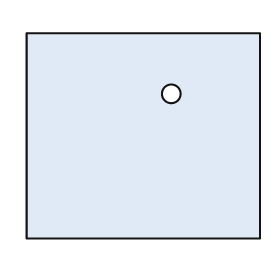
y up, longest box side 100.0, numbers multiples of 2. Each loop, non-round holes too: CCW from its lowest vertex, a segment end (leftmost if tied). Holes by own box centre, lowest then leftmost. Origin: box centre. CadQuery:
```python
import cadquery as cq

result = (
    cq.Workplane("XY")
    .moveTo(-50.0, -44.0)
    .lineTo(50.0, -44.0)
    .lineTo(50.0, 44.0)
    .lineTo(-50.0, 44.0)
    .close()
    .moveTo(12.0, 18.0)
    .circle(4.0)
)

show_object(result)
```